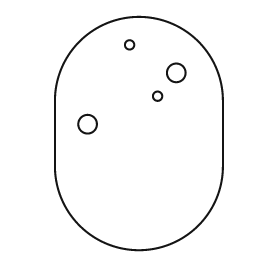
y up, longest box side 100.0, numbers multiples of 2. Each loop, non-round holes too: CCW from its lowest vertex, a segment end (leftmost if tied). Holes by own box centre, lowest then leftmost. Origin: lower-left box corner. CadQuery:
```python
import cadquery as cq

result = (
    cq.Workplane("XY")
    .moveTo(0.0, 36.0)
    .threePointArc((36.0, 0.0), (72.0, 36.0))
    .lineTo(72.0, 64.0)
    .threePointArc((36.0, 100.0), (0.0, 64.0))
    .close()
    .moveTo(14.0, 54.0)
    .circle(4.0)
    .moveTo(44.0, 66.0)
    .circle(2.0)
    .moveTo(52.0, 76.0)
    .circle(4.0)
    .moveTo(32.0, 88.0)
    .circle(2.0)
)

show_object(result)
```